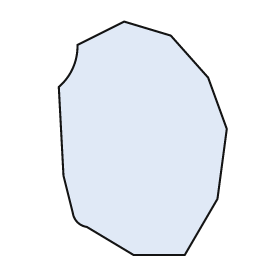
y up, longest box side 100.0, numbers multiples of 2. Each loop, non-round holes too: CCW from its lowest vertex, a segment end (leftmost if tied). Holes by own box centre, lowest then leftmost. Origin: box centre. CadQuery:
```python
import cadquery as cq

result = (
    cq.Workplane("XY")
    .moveTo(-4.0, -50.0)
    .lineTo(18.0, -50.0)
    .lineTo(32.0, -26.0)
    .lineTo(36.0, 4.0)
    .lineTo(28.0, 26.0)
    .lineTo(12.0, 44.0)
    .lineTo(-8.0, 50.0)
    .lineTo(-28.0, 40.0)
    .threePointArc((-30.0, 30.0), (-36.0, 22.0))
    .lineTo(-34.0, -16.0)
    .lineTo(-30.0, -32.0)
    .threePointArc((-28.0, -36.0), (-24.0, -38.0))
    .close()
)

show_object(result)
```